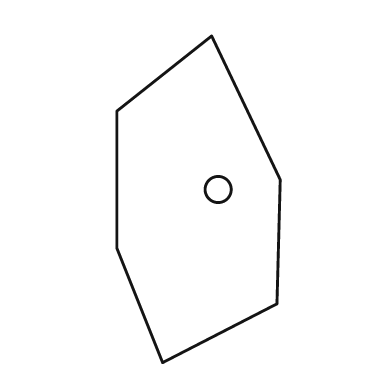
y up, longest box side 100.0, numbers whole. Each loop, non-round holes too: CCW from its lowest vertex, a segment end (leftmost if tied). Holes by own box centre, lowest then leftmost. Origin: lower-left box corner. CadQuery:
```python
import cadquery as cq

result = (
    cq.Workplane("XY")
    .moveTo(14.0, 0.0)
    .lineTo(49.0, 18.0)
    .lineTo(50.0, 56.0)
    .lineTo(29.0, 100.0)
    .lineTo(0.0, 77.0)
    .lineTo(0.0, 35.0)
    .close()
    .moveTo(31.0, 53.0)
    .circle(4.0)
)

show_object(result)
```